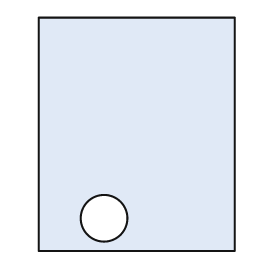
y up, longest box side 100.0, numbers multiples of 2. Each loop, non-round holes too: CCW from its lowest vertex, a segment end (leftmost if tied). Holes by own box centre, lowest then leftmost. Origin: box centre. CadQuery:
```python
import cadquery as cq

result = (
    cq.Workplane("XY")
    .moveTo(-42.0, -50.0)
    .lineTo(42.0, -50.0)
    .lineTo(42.0, 50.0)
    .lineTo(-42.0, 50.0)
    .close()
    .moveTo(-14.0, -36.0)
    .circle(10.0)
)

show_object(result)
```